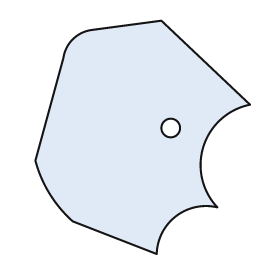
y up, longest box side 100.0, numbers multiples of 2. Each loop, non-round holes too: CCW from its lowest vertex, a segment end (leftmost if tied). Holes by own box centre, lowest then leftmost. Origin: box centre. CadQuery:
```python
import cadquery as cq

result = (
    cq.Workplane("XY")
    .moveTo(6.0, -50.0)
    .threePointArc((14.0, -34.0), (32.0, -30.0))
    .threePointArc((26.0, -4.0), (46.0, 14.0))
    .lineTo(8.0, 50.0)
    .lineTo(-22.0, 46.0)
    .threePointArc((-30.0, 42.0), (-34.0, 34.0))
    .lineTo(-46.0, -10.0)
    .threePointArc((-40.0, -24.0), (-30.0, -36.0))
    .close()
    .moveTo(12.0, 4.0)
    .circle(4.0)
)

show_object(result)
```